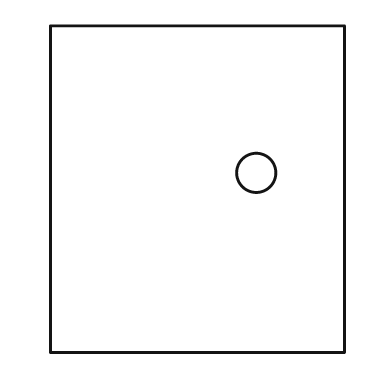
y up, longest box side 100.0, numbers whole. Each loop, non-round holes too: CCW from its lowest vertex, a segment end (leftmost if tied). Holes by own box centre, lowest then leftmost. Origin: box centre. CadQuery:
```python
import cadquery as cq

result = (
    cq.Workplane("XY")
    .moveTo(-45.0, -50.0)
    .lineTo(45.0, -50.0)
    .lineTo(45.0, 50.0)
    .lineTo(-45.0, 50.0)
    .close()
    .moveTo(18.0, 5.0)
    .circle(6.0)
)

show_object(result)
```